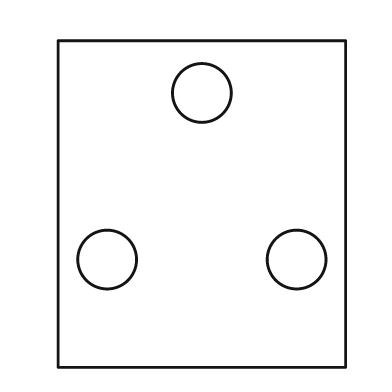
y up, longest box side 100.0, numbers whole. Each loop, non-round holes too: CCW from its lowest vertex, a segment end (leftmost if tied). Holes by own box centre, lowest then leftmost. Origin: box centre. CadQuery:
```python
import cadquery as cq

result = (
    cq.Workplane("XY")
    .moveTo(-44.0, -50.0)
    .lineTo(44.0, -50.0)
    .lineTo(44.0, 50.0)
    .lineTo(-44.0, 50.0)
    .close()
    .moveTo(-29.0, -17.0)
    .circle(9.0)
    .moveTo(29.0, -17.0)
    .circle(9.0)
    .moveTo(0.0, 34.0)
    .circle(9.0)
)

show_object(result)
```